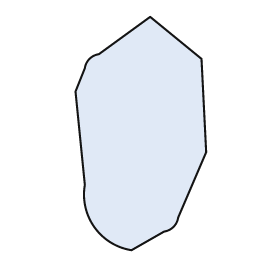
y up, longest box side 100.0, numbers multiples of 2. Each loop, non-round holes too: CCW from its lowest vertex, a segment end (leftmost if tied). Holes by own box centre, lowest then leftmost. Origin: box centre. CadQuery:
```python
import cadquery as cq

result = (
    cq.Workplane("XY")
    .moveTo(-4.0, -50.0)
    .lineTo(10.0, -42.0)
    .threePointArc((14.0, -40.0), (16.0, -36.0))
    .lineTo(28.0, -8.0)
    .lineTo(26.0, 32.0)
    .lineTo(4.0, 50.0)
    .lineTo(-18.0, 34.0)
    .threePointArc((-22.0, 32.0), (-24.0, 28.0))
    .lineTo(-28.0, 18.0)
    .lineTo(-24.0, -22.0)
    .threePointArc((-20.0, -40.0), (-4.0, -50.0))
    .close()
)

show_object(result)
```